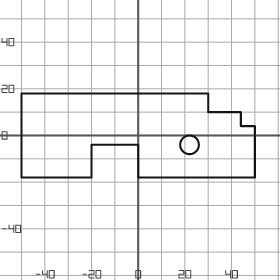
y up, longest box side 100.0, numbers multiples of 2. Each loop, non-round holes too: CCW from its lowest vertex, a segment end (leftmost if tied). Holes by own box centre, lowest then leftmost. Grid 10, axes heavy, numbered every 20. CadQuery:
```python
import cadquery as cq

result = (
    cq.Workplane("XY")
    .moveTo(-50.0, -18.0)
    .lineTo(-20.0, -18.0)
    .lineTo(-20.0, -4.0)
    .lineTo(0.0, -4.0)
    .lineTo(0.0, -18.0)
    .lineTo(50.0, -18.0)
    .lineTo(50.0, 4.0)
    .lineTo(44.0, 4.0)
    .lineTo(44.0, 10.0)
    .lineTo(30.0, 10.0)
    .lineTo(30.0, 18.0)
    .lineTo(-50.0, 18.0)
    .close()
    .moveTo(22.0, -4.0)
    .circle(4.0)
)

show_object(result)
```